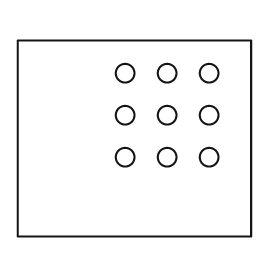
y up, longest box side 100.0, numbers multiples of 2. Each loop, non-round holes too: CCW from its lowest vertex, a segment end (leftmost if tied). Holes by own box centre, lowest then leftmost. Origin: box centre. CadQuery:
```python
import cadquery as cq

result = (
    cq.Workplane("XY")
    .moveTo(-50.0, -42.0)
    .lineTo(50.0, -42.0)
    .lineTo(50.0, 42.0)
    .lineTo(-50.0, 42.0)
    .close()
    .moveTo(-4.0, -8.0)
    .circle(4.0)
    .moveTo(14.0, -8.0)
    .circle(4.0)
    .moveTo(32.0, -8.0)
    .circle(4.0)
    .moveTo(-4.0, 10.0)
    .circle(4.0)
    .moveTo(14.0, 10.0)
    .circle(4.0)
    .moveTo(32.0, 10.0)
    .circle(4.0)
    .moveTo(-4.0, 28.0)
    .circle(4.0)
    .moveTo(14.0, 28.0)
    .circle(4.0)
    .moveTo(32.0, 28.0)
    .circle(4.0)
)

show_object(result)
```